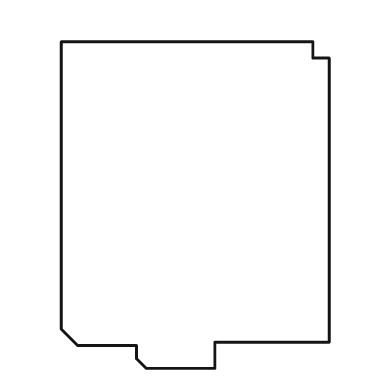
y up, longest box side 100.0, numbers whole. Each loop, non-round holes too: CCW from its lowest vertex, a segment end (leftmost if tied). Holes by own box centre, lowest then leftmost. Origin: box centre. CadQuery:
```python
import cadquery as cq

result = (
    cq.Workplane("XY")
    .moveTo(-15.0, -50.0)
    .lineTo(6.0, -50.0)
    .lineTo(6.0, -42.0)
    .lineTo(41.0, -42.0)
    .lineTo(41.0, 45.0)
    .lineTo(36.0, 45.0)
    .lineTo(36.0, 50.0)
    .lineTo(-41.0, 50.0)
    .lineTo(-41.0, -38.0)
    .lineTo(-36.0, -43.0)
    .lineTo(-18.0, -43.0)
    .lineTo(-18.0, -47.0)
    .close()
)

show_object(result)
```